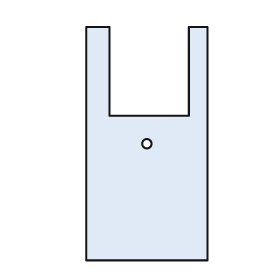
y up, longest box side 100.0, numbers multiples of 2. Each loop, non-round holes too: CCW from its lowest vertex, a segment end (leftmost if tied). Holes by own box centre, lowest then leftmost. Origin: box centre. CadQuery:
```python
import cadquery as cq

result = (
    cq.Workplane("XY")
    .moveTo(-26.0, -50.0)
    .lineTo(26.0, -50.0)
    .lineTo(26.0, 50.0)
    .lineTo(18.0, 50.0)
    .lineTo(18.0, 12.0)
    .lineTo(-16.0, 12.0)
    .lineTo(-16.0, 50.0)
    .lineTo(-26.0, 50.0)
    .close()
    .moveTo(0.0, 0.0)
    .circle(2.0)
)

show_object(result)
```